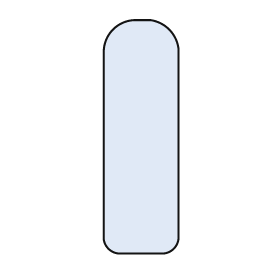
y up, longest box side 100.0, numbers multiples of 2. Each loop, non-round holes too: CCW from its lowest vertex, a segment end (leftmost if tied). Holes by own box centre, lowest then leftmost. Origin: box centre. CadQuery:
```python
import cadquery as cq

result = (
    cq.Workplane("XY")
    .moveTo(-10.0, -50.0)
    .lineTo(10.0, -50.0)
    .threePointArc((14.0, -48.0), (16.0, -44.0))
    .lineTo(16.0, 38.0)
    .threePointArc((12.0, 46.0), (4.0, 50.0))
    .lineTo(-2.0, 50.0)
    .threePointArc((-12.0, 46.0), (-16.0, 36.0))
    .lineTo(-16.0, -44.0)
    .threePointArc((-14.0, -48.0), (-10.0, -50.0))
    .close()
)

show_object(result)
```